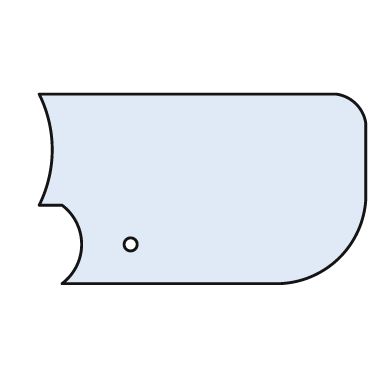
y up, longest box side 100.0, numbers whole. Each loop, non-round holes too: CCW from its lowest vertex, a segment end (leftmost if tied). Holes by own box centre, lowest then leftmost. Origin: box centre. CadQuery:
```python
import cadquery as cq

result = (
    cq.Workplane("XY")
    .moveTo(-43.0, -29.0)
    .lineTo(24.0, -29.0)
    .threePointArc((42.0, -21.0), (50.0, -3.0))
    .lineTo(50.0, 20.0)
    .threePointArc((47.0, 26.0), (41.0, 29.0))
    .lineTo(-50.0, 29.0)
    .threePointArc((-46.0, 12.0), (-50.0, -5.0))
    .lineTo(-43.0, -5.0)
    .threePointArc((-37.0, -17.0), (-43.0, -29.0))
    .close()
    .moveTo(-22.0, -17.0)
    .circle(2.0)
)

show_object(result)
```